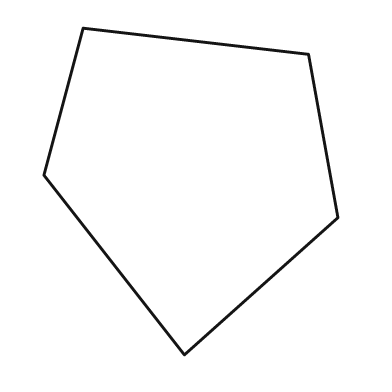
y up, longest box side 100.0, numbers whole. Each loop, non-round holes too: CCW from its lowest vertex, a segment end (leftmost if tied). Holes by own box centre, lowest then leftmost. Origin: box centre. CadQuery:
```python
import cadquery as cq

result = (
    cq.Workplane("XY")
    .moveTo(-2.0, -50.0)
    .lineTo(45.0, -8.0)
    .lineTo(36.0, 42.0)
    .lineTo(-33.0, 50.0)
    .lineTo(-45.0, 5.0)
    .close()
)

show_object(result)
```